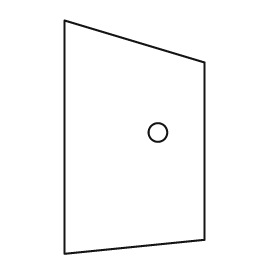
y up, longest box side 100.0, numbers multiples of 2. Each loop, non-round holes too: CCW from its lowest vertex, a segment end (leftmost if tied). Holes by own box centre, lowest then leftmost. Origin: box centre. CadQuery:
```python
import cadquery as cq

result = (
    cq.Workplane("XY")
    .moveTo(-30.0, -50.0)
    .lineTo(30.0, -44.0)
    .lineTo(30.0, 32.0)
    .lineTo(-30.0, 50.0)
    .close()
    .moveTo(10.0, 2.0)
    .circle(4.0)
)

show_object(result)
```